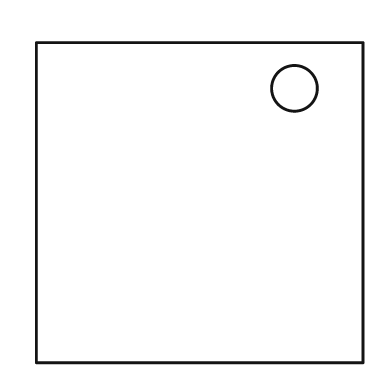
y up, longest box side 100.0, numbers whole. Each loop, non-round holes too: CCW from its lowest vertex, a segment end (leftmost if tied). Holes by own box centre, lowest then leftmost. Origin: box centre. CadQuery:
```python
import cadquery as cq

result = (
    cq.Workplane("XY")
    .moveTo(-50.0, -49.0)
    .lineTo(50.0, -49.0)
    .lineTo(50.0, 49.0)
    .lineTo(-50.0, 49.0)
    .close()
    .moveTo(29.0, 35.0)
    .circle(7.0)
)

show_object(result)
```